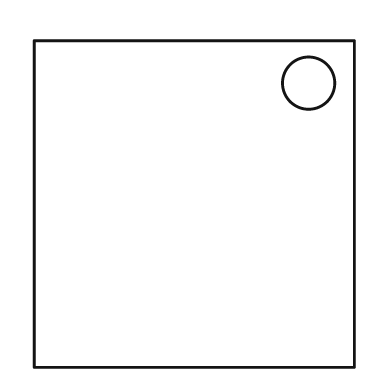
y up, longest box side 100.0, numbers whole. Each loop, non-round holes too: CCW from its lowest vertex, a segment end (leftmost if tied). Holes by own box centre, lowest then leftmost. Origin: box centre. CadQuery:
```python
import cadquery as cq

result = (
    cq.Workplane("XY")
    .moveTo(-49.0, -50.0)
    .lineTo(49.0, -50.0)
    .lineTo(49.0, 50.0)
    .lineTo(-49.0, 50.0)
    .close()
    .moveTo(35.0, 37.0)
    .circle(8.0)
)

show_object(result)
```